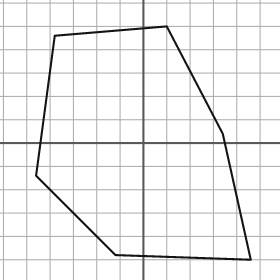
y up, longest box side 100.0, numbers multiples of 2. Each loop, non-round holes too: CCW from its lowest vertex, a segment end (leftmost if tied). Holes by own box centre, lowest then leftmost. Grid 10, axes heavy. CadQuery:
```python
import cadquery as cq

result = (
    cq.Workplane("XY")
    .moveTo(46.0, -50.0)
    .lineTo(34.0, 4.0)
    .lineTo(10.0, 50.0)
    .lineTo(-38.0, 46.0)
    .lineTo(-46.0, -14.0)
    .lineTo(-12.0, -48.0)
    .close()
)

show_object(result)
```